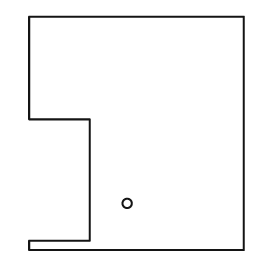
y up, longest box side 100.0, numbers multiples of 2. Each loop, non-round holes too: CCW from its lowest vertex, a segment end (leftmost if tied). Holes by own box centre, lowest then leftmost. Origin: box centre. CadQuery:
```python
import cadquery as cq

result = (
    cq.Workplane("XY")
    .moveTo(-46.0, -50.0)
    .lineTo(46.0, -50.0)
    .lineTo(46.0, 50.0)
    .lineTo(-46.0, 50.0)
    .lineTo(-46.0, 6.0)
    .lineTo(-20.0, 6.0)
    .lineTo(-20.0, -46.0)
    .lineTo(-46.0, -46.0)
    .close()
    .moveTo(-4.0, -30.0)
    .circle(2.0)
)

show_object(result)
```